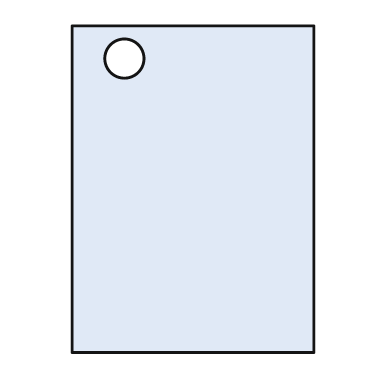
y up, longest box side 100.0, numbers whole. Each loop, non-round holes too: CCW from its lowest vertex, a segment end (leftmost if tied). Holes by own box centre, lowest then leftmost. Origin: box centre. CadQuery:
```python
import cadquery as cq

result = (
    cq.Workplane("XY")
    .moveTo(-37.0, -50.0)
    .lineTo(37.0, -50.0)
    .lineTo(37.0, 50.0)
    .lineTo(-37.0, 50.0)
    .close()
    .moveTo(-21.0, 40.0)
    .circle(6.0)
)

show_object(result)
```